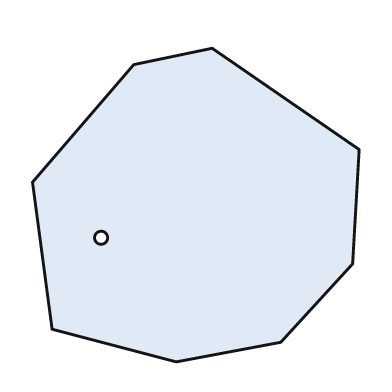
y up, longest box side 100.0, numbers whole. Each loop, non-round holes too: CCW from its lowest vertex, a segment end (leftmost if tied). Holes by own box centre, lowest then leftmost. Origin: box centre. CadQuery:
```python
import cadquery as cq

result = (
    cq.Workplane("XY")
    .moveTo(-6.0, -48.0)
    .lineTo(26.0, -42.0)
    .lineTo(48.0, -18.0)
    .lineTo(50.0, 17.0)
    .lineTo(5.0, 48.0)
    .lineTo(-19.0, 43.0)
    .lineTo(-50.0, 7.0)
    .lineTo(-44.0, -38.0)
    .close()
    .moveTo(-29.0, -10.0)
    .circle(2.0)
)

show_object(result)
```